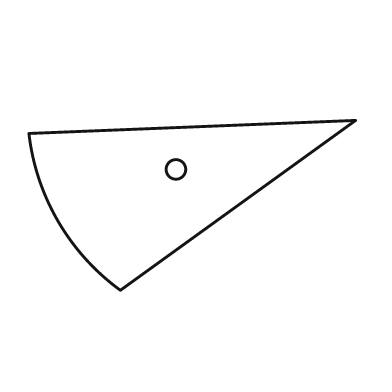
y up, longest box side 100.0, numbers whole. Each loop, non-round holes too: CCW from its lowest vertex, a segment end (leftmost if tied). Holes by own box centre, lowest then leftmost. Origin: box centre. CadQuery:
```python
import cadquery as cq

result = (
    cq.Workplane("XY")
    .moveTo(-22.0, -26.0)
    .lineTo(50.0, 26.0)
    .lineTo(-50.0, 22.0)
    .threePointArc((-41.0, -5.0), (-22.0, -26.0))
    .close()
    .moveTo(-5.0, 11.0)
    .circle(3.0)
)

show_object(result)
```